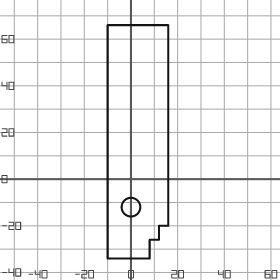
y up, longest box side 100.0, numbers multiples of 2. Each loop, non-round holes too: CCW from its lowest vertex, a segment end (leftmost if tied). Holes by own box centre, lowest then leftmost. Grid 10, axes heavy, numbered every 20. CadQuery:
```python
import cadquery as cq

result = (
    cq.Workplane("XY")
    .moveTo(-10.0, -34.0)
    .lineTo(8.0, -34.0)
    .lineTo(8.0, -26.0)
    .lineTo(12.0, -26.0)
    .lineTo(12.0, -20.0)
    .lineTo(16.0, -20.0)
    .lineTo(16.0, 66.0)
    .lineTo(-10.0, 66.0)
    .close()
    .moveTo(0.0, -12.0)
    .circle(4.0)
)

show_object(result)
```